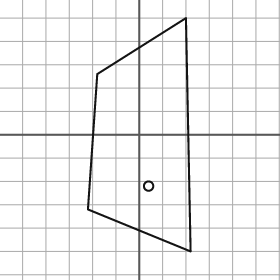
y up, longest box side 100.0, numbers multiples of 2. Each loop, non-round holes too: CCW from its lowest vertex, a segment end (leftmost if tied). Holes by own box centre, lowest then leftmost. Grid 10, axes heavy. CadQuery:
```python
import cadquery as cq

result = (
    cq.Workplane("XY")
    .moveTo(22.0, -50.0)
    .lineTo(20.0, 50.0)
    .lineTo(-18.0, 26.0)
    .lineTo(-22.0, -32.0)
    .close()
    .moveTo(4.0, -22.0)
    .circle(2.0)
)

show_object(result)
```